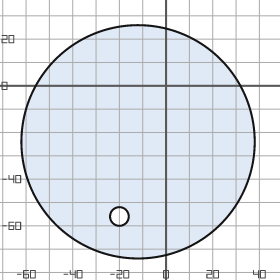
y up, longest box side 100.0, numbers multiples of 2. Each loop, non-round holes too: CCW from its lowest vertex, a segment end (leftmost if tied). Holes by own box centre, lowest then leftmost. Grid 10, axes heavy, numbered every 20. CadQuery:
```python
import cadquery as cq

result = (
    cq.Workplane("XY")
    .moveTo(-12.0, -24.0)
    .circle(50.0)
    .moveTo(-20.0, -56.0)
    .circle(4.0)
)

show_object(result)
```